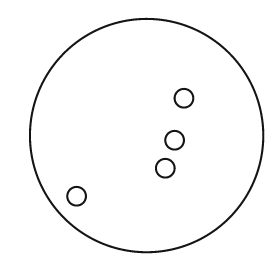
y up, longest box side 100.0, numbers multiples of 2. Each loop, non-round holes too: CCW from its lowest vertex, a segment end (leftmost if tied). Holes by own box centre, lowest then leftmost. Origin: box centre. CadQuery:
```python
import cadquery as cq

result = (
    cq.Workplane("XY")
    .moveTo(0.0, 0.0)
    .circle(50.0)
    .moveTo(-30.0, -26.0)
    .circle(4.0)
    .moveTo(8.0, -14.0)
    .circle(4.0)
    .moveTo(12.0, -2.0)
    .circle(4.0)
    .moveTo(16.0, 16.0)
    .circle(4.0)
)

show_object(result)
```